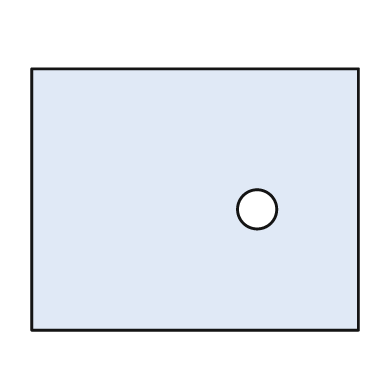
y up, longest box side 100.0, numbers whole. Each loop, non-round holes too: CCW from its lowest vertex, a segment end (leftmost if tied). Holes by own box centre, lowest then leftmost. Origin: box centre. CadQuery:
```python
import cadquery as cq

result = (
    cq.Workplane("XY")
    .moveTo(-50.0, -40.0)
    .lineTo(50.0, -40.0)
    .lineTo(50.0, 40.0)
    .lineTo(-50.0, 40.0)
    .close()
    .moveTo(19.0, -3.0)
    .circle(6.0)
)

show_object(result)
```